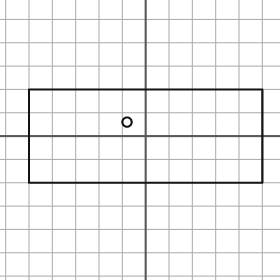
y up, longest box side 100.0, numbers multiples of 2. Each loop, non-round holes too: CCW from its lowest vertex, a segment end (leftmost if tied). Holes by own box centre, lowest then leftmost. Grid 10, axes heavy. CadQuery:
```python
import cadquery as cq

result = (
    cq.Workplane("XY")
    .moveTo(-50.0, -20.0)
    .lineTo(50.0, -20.0)
    .lineTo(50.0, 20.0)
    .lineTo(-50.0, 20.0)
    .close()
    .moveTo(-8.0, 6.0)
    .circle(2.0)
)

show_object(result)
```